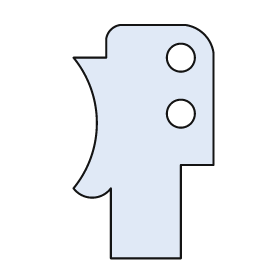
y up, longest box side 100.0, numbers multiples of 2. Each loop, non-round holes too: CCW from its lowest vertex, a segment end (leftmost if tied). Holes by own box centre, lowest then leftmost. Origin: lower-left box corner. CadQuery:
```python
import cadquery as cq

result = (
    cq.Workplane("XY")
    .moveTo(16.0, 0.0)
    .lineTo(46.0, 0.0)
    .lineTo(46.0, 40.0)
    .lineTo(60.0, 40.0)
    .lineTo(60.0, 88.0)
    .threePointArc((56.0, 96.0), (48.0, 100.0))
    .lineTo(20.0, 100.0)
    .threePointArc((16.0, 98.0), (14.0, 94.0))
    .lineTo(14.0, 86.0)
    .lineTo(0.0, 86.0)
    .threePointArc((10.0, 58.0), (0.0, 30.0))
    .threePointArc((8.0, 26.0), (16.0, 30.0))
    .close()
    .moveTo(46.0, 62.0)
    .circle(6.0)
    .moveTo(46.0, 86.0)
    .circle(6.0)
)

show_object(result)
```